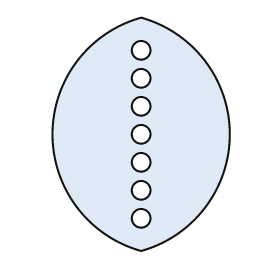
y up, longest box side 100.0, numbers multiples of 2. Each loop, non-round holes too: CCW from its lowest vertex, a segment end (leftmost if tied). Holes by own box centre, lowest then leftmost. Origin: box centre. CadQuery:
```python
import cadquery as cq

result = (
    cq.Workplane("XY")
    .moveTo(0.0, -50.0)
    .threePointArc((38.0, 0.0), (0.0, 50.0))
    .threePointArc((-38.0, 0.0), (0.0, -50.0))
    .close()
    .moveTo(0.0, -36.0)
    .circle(4.0)
    .moveTo(0.0, -24.0)
    .circle(4.0)
    .moveTo(0.0, -12.0)
    .circle(4.0)
    .moveTo(0.0, 0.0)
    .circle(4.0)
    .moveTo(0.0, 12.0)
    .circle(4.0)
    .moveTo(0.0, 24.0)
    .circle(4.0)
    .moveTo(0.0, 36.0)
    .circle(4.0)
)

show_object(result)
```